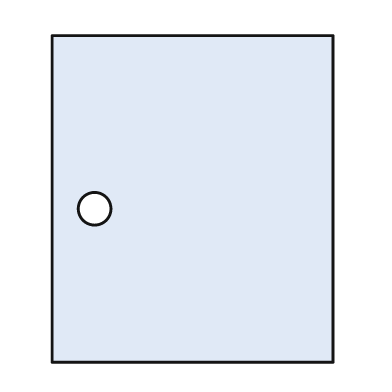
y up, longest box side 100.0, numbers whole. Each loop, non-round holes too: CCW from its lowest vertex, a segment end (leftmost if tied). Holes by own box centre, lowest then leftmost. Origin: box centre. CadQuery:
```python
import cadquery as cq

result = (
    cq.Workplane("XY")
    .moveTo(-43.0, -50.0)
    .lineTo(43.0, -50.0)
    .lineTo(43.0, 50.0)
    .lineTo(-43.0, 50.0)
    .close()
    .moveTo(-30.0, -3.0)
    .circle(5.0)
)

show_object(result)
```